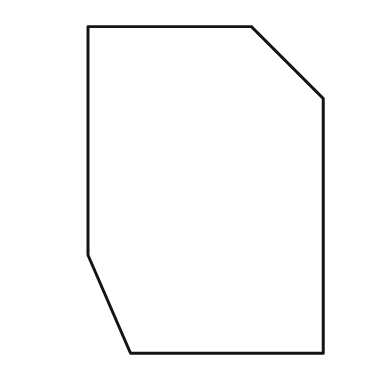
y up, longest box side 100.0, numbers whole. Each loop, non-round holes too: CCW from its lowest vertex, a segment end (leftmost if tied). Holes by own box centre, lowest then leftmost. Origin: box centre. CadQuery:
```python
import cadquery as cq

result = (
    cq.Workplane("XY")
    .moveTo(-23.0, -50.0)
    .lineTo(36.0, -50.0)
    .lineTo(36.0, 28.0)
    .lineTo(14.0, 50.0)
    .lineTo(-36.0, 50.0)
    .lineTo(-36.0, -20.0)
    .close()
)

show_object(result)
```